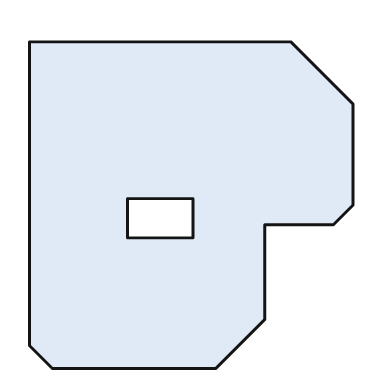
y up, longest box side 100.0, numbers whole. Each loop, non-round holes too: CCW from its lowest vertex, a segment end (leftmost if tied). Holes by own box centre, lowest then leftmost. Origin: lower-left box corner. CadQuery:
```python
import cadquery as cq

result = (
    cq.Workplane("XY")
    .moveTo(7.0, 0.0)
    .lineTo(57.0, 0.0)
    .lineTo(72.0, 15.0)
    .lineTo(72.0, 44.0)
    .lineTo(93.0, 44.0)
    .lineTo(99.0, 50.0)
    .lineTo(99.0, 81.0)
    .lineTo(80.0, 100.0)
    .lineTo(0.0, 100.0)
    .lineTo(0.0, 7.0)
    .close()
    .moveTo(30.0, 40.0)
    .lineTo(50.0, 40.0)
    .lineTo(50.0, 52.0)
    .lineTo(30.0, 52.0)
    .close()
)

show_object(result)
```